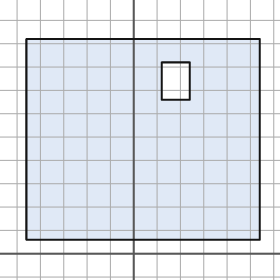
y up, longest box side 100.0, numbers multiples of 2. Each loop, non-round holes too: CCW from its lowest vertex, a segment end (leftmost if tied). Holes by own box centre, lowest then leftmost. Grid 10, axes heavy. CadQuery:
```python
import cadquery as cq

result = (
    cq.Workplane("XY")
    .moveTo(-46.0, 6.0)
    .lineTo(54.0, 6.0)
    .lineTo(54.0, 92.0)
    .lineTo(-46.0, 92.0)
    .close()
    .moveTo(12.0, 66.0)
    .lineTo(24.0, 66.0)
    .lineTo(24.0, 82.0)
    .lineTo(12.0, 82.0)
    .close()
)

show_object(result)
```